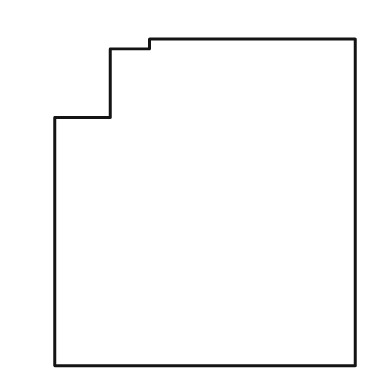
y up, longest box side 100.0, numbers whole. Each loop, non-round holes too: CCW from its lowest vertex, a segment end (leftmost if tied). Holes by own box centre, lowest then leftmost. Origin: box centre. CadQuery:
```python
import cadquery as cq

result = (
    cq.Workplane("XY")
    .moveTo(-46.0, -50.0)
    .lineTo(46.0, -50.0)
    .lineTo(46.0, 50.0)
    .lineTo(-17.0, 50.0)
    .lineTo(-17.0, 47.0)
    .lineTo(-29.0, 47.0)
    .lineTo(-29.0, 26.0)
    .lineTo(-46.0, 26.0)
    .close()
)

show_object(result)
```